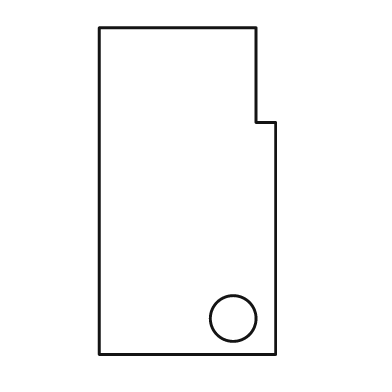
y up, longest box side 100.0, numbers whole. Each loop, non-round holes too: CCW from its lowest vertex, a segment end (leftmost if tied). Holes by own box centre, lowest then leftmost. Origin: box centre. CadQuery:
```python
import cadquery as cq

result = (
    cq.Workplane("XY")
    .moveTo(-27.0, -50.0)
    .lineTo(27.0, -50.0)
    .lineTo(27.0, 21.0)
    .lineTo(21.0, 21.0)
    .lineTo(21.0, 50.0)
    .lineTo(-27.0, 50.0)
    .close()
    .moveTo(14.0, -39.0)
    .circle(7.0)
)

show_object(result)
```